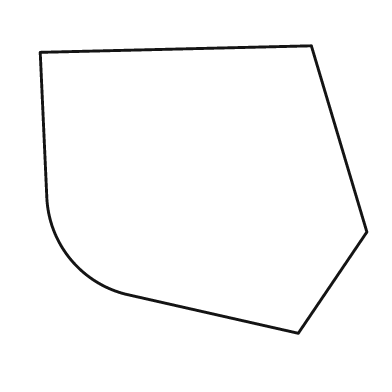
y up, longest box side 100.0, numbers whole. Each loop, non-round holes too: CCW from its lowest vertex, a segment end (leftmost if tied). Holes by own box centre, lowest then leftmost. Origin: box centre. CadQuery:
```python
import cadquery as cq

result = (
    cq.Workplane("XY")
    .moveTo(29.0, -44.0)
    .lineTo(50.0, -13.0)
    .lineTo(33.0, 44.0)
    .lineTo(-50.0, 42.0)
    .lineTo(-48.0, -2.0)
    .threePointArc((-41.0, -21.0), (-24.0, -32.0))
    .close()
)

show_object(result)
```